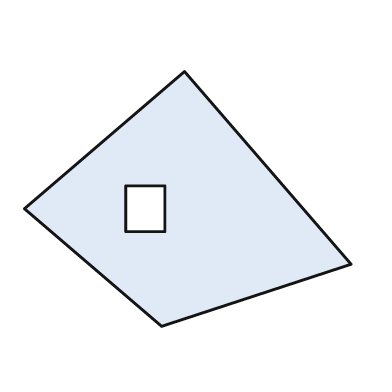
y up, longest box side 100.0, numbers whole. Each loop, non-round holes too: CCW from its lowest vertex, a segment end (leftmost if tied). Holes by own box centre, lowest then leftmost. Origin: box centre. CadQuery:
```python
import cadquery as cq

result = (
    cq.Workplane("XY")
    .moveTo(-8.0, -39.0)
    .lineTo(50.0, -20.0)
    .lineTo(-1.0, 39.0)
    .lineTo(-50.0, -3.0)
    .close()
    .moveTo(-19.0, -10.0)
    .lineTo(-7.0, -10.0)
    .lineTo(-7.0, 4.0)
    .lineTo(-19.0, 4.0)
    .close()
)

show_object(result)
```